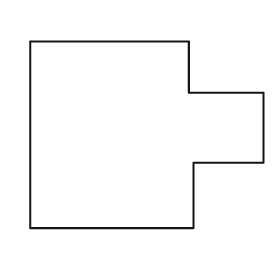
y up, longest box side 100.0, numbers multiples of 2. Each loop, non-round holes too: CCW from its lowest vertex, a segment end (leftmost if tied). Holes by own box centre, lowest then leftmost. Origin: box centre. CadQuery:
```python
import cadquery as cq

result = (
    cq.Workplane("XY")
    .moveTo(-50.0, -40.0)
    .lineTo(20.0, -40.0)
    .lineTo(20.0, -12.0)
    .lineTo(50.0, -12.0)
    .lineTo(50.0, 18.0)
    .lineTo(18.0, 18.0)
    .lineTo(18.0, 40.0)
    .lineTo(-50.0, 40.0)
    .close()
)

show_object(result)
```